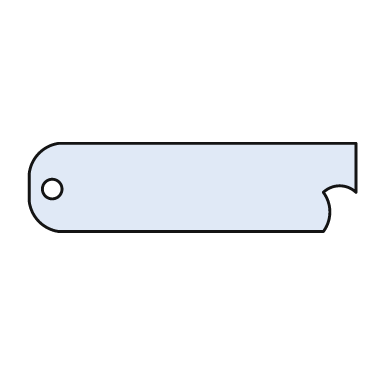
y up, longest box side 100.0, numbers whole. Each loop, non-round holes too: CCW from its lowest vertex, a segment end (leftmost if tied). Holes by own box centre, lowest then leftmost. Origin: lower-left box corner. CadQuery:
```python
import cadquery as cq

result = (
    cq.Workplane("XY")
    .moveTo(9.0, 0.0)
    .lineTo(90.0, 0.0)
    .threePointArc((92.0, 6.0), (90.0, 12.0))
    .threePointArc((95.0, 14.0), (100.0, 12.0))
    .lineTo(100.0, 27.0)
    .lineTo(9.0, 27.0)
    .threePointArc((3.0, 24.0), (0.0, 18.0))
    .lineTo(0.0, 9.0)
    .threePointArc((3.0, 3.0), (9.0, 0.0))
    .close()
    .moveTo(7.0, 13.0)
    .circle(3.0)
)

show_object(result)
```